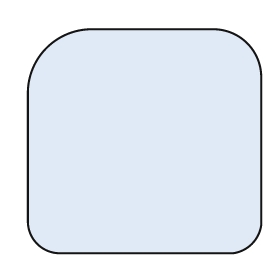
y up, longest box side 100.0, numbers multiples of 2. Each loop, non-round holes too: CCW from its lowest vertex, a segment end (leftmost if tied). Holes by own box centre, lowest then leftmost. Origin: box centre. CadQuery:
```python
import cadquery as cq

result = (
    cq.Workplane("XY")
    .moveTo(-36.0, -48.0)
    .lineTo(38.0, -48.0)
    .threePointArc((46.0, -44.0), (50.0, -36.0))
    .lineTo(50.0, 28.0)
    .threePointArc((44.0, 42.0), (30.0, 48.0))
    .lineTo(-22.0, 48.0)
    .threePointArc((-42.0, 40.0), (-50.0, 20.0))
    .lineTo(-50.0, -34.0)
    .threePointArc((-46.0, -44.0), (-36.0, -48.0))
    .close()
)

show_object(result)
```